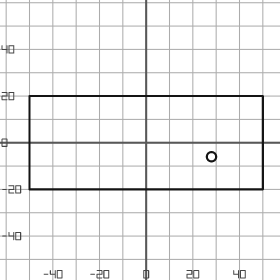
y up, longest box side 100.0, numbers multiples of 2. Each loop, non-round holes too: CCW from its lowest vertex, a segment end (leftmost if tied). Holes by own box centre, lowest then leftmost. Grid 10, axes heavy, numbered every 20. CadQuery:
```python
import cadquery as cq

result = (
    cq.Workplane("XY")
    .moveTo(-50.0, -20.0)
    .lineTo(50.0, -20.0)
    .lineTo(50.0, 20.0)
    .lineTo(-50.0, 20.0)
    .close()
    .moveTo(28.0, -6.0)
    .circle(2.0)
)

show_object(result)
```